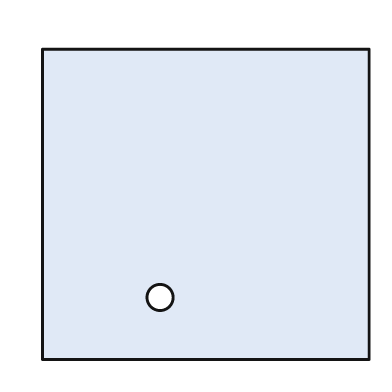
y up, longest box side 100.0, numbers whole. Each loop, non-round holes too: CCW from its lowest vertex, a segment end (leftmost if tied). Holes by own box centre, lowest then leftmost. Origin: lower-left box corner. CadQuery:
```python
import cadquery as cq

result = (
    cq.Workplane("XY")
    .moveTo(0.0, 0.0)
    .lineTo(100.0, 0.0)
    .lineTo(100.0, 95.0)
    .lineTo(0.0, 95.0)
    .close()
    .moveTo(36.0, 19.0)
    .circle(4.0)
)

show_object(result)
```